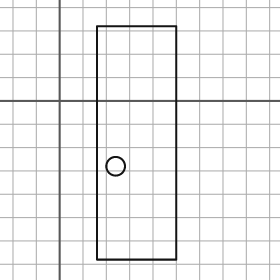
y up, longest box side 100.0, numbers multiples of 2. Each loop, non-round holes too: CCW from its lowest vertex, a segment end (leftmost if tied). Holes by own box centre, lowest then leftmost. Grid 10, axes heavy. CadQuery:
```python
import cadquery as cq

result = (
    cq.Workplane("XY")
    .moveTo(16.0, -68.0)
    .lineTo(50.0, -68.0)
    .lineTo(50.0, 32.0)
    .lineTo(16.0, 32.0)
    .close()
    .moveTo(24.0, -28.0)
    .circle(4.0)
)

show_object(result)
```